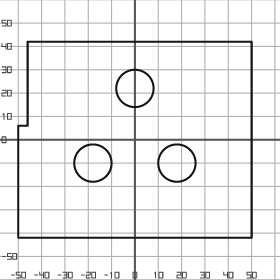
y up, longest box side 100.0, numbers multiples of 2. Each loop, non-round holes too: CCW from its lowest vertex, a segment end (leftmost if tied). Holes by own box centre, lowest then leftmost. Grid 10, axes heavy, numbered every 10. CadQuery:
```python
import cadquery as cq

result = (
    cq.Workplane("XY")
    .moveTo(-50.0, -42.0)
    .lineTo(50.0, -42.0)
    .lineTo(50.0, 42.0)
    .lineTo(-46.0, 42.0)
    .lineTo(-46.0, 6.0)
    .lineTo(-50.0, 6.0)
    .close()
    .moveTo(-18.0, -10.0)
    .circle(8.0)
    .moveTo(18.0, -10.0)
    .circle(8.0)
    .moveTo(0.0, 22.0)
    .circle(8.0)
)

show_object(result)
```